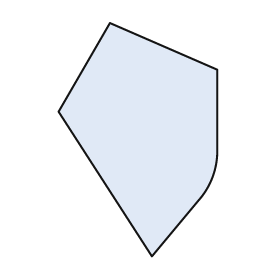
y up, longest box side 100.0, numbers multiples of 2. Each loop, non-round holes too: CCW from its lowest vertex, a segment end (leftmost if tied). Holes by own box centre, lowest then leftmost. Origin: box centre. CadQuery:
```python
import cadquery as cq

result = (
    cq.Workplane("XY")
    .moveTo(6.0, -50.0)
    .lineTo(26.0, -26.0)
    .threePointArc((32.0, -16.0), (34.0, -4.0))
    .lineTo(34.0, 30.0)
    .lineTo(-12.0, 50.0)
    .lineTo(-34.0, 12.0)
    .close()
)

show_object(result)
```